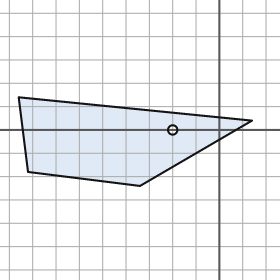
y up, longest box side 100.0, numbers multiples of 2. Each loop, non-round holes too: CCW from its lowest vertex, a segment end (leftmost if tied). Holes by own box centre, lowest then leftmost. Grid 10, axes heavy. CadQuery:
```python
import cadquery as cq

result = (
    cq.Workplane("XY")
    .moveTo(-34.0, -24.0)
    .lineTo(14.0, 4.0)
    .lineTo(-86.0, 14.0)
    .lineTo(-82.0, -18.0)
    .close()
    .moveTo(-20.0, 0.0)
    .circle(2.0)
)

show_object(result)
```